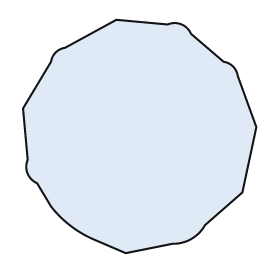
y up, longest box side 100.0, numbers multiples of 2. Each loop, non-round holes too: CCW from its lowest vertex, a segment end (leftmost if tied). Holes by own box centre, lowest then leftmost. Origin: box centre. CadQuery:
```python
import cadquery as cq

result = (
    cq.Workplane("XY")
    .moveTo(-6.0, -50.0)
    .lineTo(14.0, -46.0)
    .threePointArc((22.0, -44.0), (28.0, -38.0))
    .lineTo(44.0, -24.0)
    .lineTo(50.0, 4.0)
    .lineTo(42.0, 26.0)
    .threePointArc((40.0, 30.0), (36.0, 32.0))
    .lineTo(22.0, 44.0)
    .threePointArc((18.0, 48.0), (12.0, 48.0))
    .lineTo(-10.0, 50.0)
    .lineTo(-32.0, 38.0)
    .threePointArc((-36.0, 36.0), (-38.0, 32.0))
    .lineTo(-50.0, 12.0)
    .lineTo(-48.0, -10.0)
    .threePointArc((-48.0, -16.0), (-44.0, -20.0))
    .lineTo(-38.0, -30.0)
    .threePointArc((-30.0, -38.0), (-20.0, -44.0))
    .close()
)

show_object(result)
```